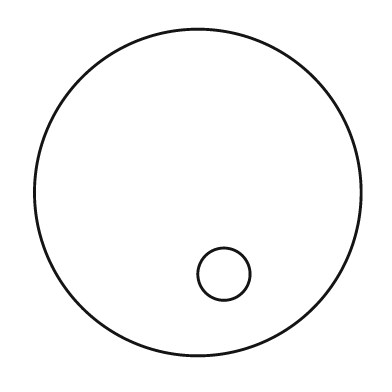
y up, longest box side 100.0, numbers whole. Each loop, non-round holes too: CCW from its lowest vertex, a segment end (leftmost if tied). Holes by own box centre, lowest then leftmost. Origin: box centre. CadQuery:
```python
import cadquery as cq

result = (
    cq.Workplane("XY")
    .moveTo(0.0, 0.0)
    .circle(50.0)
    .moveTo(8.0, -25.0)
    .circle(8.0)
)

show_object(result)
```